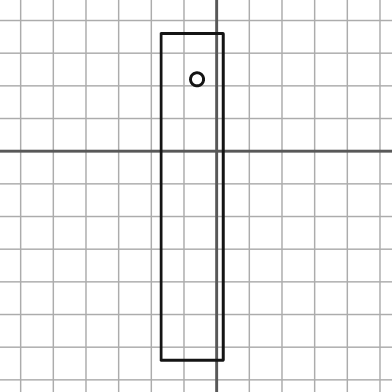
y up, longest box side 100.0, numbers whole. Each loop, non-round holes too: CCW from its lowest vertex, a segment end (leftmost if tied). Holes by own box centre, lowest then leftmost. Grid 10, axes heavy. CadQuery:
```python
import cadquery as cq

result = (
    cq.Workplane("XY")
    .moveTo(-17.0, -64.0)
    .lineTo(2.0, -64.0)
    .lineTo(2.0, 36.0)
    .lineTo(-17.0, 36.0)
    .close()
    .moveTo(-6.0, 22.0)
    .circle(2.0)
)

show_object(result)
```